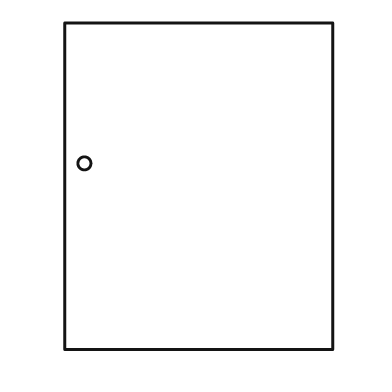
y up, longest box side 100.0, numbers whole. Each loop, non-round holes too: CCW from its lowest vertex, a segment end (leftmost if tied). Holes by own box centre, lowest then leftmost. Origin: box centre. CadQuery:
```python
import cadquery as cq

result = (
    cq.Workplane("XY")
    .moveTo(-41.0, -50.0)
    .lineTo(41.0, -50.0)
    .lineTo(41.0, 50.0)
    .lineTo(-41.0, 50.0)
    .close()
    .moveTo(-35.0, 7.0)
    .circle(2.0)
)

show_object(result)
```